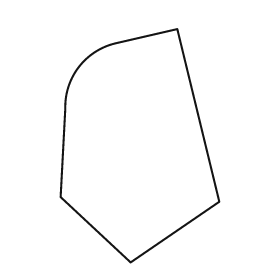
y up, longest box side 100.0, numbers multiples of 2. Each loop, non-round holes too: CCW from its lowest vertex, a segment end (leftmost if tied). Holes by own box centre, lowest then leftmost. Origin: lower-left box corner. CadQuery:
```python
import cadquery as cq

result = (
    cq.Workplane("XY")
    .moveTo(30.0, 0.0)
    .lineTo(68.0, 26.0)
    .lineTo(50.0, 100.0)
    .lineTo(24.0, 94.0)
    .threePointArc((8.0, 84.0), (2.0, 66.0))
    .lineTo(0.0, 28.0)
    .close()
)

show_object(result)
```